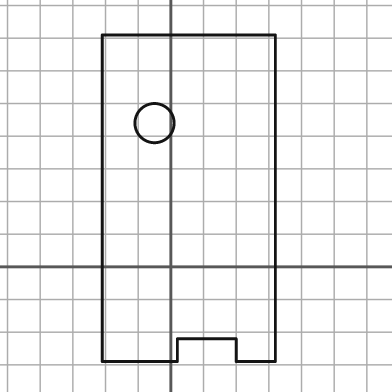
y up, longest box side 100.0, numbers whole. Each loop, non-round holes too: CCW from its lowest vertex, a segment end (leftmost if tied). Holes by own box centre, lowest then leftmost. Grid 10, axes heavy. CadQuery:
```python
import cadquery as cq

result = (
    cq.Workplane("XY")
    .moveTo(-21.0, -29.0)
    .lineTo(2.0, -29.0)
    .lineTo(2.0, -22.0)
    .lineTo(20.0, -22.0)
    .lineTo(20.0, -29.0)
    .lineTo(32.0, -29.0)
    .lineTo(32.0, 71.0)
    .lineTo(-21.0, 71.0)
    .close()
    .moveTo(-5.0, 44.0)
    .circle(6.0)
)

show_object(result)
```